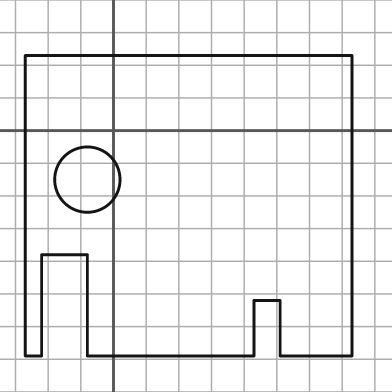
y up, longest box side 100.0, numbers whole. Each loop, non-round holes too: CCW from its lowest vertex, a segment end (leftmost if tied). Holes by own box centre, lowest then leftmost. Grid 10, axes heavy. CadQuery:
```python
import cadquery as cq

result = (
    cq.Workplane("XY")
    .moveTo(-27.0, -69.0)
    .lineTo(-22.0, -69.0)
    .lineTo(-22.0, -38.0)
    .lineTo(-8.0, -38.0)
    .lineTo(-8.0, -69.0)
    .lineTo(43.0, -69.0)
    .lineTo(43.0, -52.0)
    .lineTo(51.0, -52.0)
    .lineTo(51.0, -69.0)
    .lineTo(73.0, -69.0)
    .lineTo(73.0, 23.0)
    .lineTo(-27.0, 23.0)
    .close()
    .moveTo(-8.0, -15.0)
    .circle(10.0)
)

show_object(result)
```